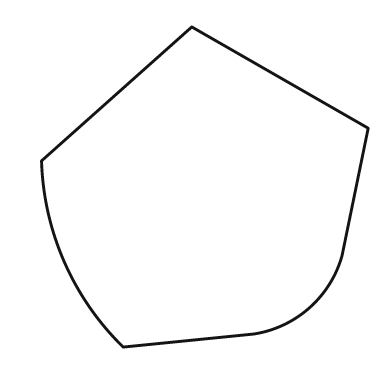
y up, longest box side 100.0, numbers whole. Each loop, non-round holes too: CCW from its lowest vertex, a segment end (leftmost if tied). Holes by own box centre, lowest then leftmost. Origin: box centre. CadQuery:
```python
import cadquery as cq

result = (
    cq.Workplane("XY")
    .moveTo(-25.0, -49.0)
    .lineTo(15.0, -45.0)
    .threePointArc((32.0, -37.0), (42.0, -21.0))
    .lineTo(50.0, 18.0)
    .lineTo(-4.0, 49.0)
    .lineTo(-50.0, 8.0)
    .threePointArc((-43.0, -23.0), (-25.0, -49.0))
    .close()
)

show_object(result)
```